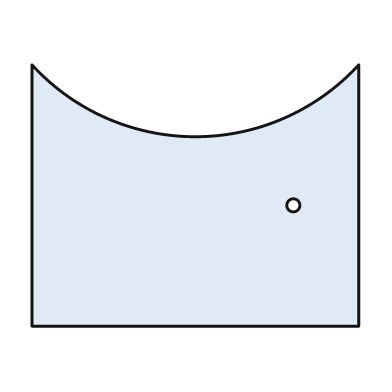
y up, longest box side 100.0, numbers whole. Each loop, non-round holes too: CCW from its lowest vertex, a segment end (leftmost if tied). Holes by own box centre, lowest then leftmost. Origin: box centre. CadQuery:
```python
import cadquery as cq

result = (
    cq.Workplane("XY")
    .moveTo(-50.0, -40.0)
    .lineTo(50.0, -40.0)
    .lineTo(50.0, 40.0)
    .threePointArc((0.0, 18.0), (-50.0, 40.0))
    .close()
    .moveTo(30.0, -3.0)
    .circle(2.0)
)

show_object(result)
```